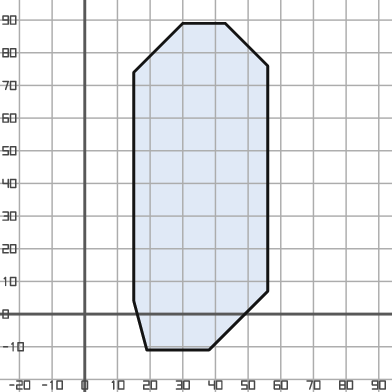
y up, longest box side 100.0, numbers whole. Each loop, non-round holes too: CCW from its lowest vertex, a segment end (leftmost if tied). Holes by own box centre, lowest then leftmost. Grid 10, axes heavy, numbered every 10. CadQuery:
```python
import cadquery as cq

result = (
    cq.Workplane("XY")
    .moveTo(19.0, -11.0)
    .lineTo(38.0, -11.0)
    .lineTo(56.0, 7.0)
    .lineTo(56.0, 76.0)
    .lineTo(43.0, 89.0)
    .lineTo(30.0, 89.0)
    .lineTo(15.0, 74.0)
    .lineTo(15.0, 4.0)
    .close()
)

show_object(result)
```